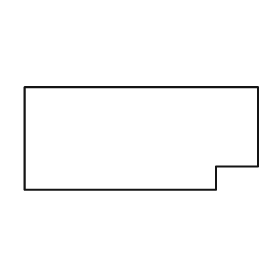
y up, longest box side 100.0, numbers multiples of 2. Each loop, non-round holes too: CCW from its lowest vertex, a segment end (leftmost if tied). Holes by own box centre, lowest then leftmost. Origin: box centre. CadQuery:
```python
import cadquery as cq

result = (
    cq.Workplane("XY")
    .moveTo(-50.0, -22.0)
    .lineTo(32.0, -22.0)
    .lineTo(32.0, -12.0)
    .lineTo(50.0, -12.0)
    .lineTo(50.0, 22.0)
    .lineTo(-50.0, 22.0)
    .close()
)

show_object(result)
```